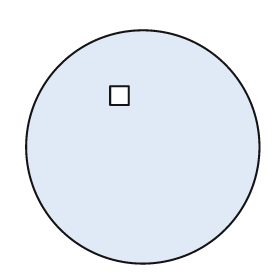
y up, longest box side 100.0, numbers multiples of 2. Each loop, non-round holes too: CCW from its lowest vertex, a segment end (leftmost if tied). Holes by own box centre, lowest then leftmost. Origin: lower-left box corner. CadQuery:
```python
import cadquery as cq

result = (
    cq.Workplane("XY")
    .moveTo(50.0, 50.0)
    .circle(50.0)
    .moveTo(36.0, 68.0)
    .lineTo(44.0, 68.0)
    .lineTo(44.0, 76.0)
    .lineTo(36.0, 76.0)
    .close()
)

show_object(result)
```